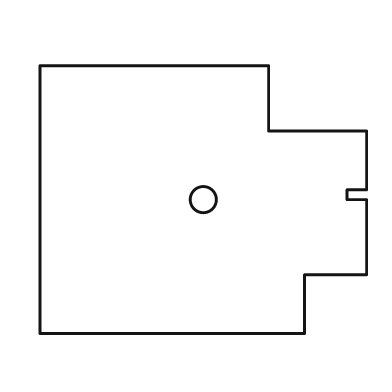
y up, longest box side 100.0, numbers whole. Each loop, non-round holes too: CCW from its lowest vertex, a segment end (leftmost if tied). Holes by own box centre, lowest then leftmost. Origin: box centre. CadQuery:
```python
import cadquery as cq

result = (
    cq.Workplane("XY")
    .moveTo(-50.0, -41.0)
    .lineTo(31.0, -41.0)
    .lineTo(31.0, -23.0)
    .lineTo(50.0, -23.0)
    .lineTo(50.0, 0.0)
    .lineTo(44.0, 0.0)
    .lineTo(44.0, 3.0)
    .lineTo(50.0, 3.0)
    .lineTo(50.0, 21.0)
    .lineTo(20.0, 21.0)
    .lineTo(20.0, 41.0)
    .lineTo(-50.0, 41.0)
    .close()
    .moveTo(0.0, 0.0)
    .circle(4.0)
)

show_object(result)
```